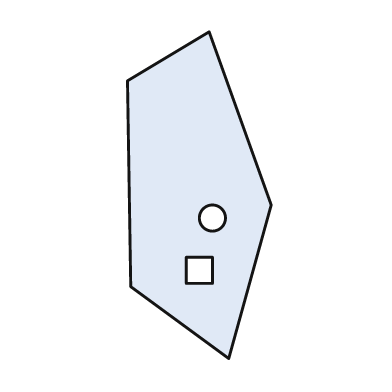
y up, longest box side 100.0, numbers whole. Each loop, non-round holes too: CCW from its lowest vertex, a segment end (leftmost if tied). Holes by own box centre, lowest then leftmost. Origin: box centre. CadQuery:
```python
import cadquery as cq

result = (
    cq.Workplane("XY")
    .moveTo(9.0, -50.0)
    .lineTo(22.0, -3.0)
    .lineTo(3.0, 50.0)
    .lineTo(-22.0, 35.0)
    .lineTo(-21.0, -28.0)
    .close()
    .moveTo(-4.0, -27.0)
    .lineTo(4.0, -27.0)
    .lineTo(4.0, -19.0)
    .lineTo(-4.0, -19.0)
    .close()
    .moveTo(4.0, -7.0)
    .circle(4.0)
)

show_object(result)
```